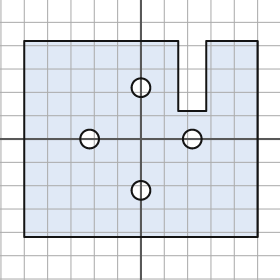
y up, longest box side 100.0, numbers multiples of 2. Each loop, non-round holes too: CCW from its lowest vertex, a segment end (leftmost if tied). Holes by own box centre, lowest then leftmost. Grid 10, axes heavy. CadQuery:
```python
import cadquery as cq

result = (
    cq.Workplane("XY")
    .moveTo(-50.0, -42.0)
    .lineTo(50.0, -42.0)
    .lineTo(50.0, 42.0)
    .lineTo(28.0, 42.0)
    .lineTo(28.0, 12.0)
    .lineTo(16.0, 12.0)
    .lineTo(16.0, 42.0)
    .lineTo(-50.0, 42.0)
    .close()
    .moveTo(0.0, -22.0)
    .circle(4.0)
    .moveTo(-22.0, 0.0)
    .circle(4.0)
    .moveTo(22.0, 0.0)
    .circle(4.0)
    .moveTo(0.0, 22.0)
    .circle(4.0)
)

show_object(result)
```